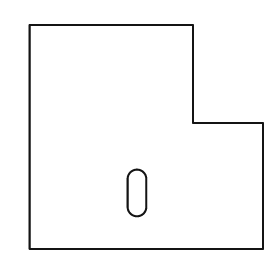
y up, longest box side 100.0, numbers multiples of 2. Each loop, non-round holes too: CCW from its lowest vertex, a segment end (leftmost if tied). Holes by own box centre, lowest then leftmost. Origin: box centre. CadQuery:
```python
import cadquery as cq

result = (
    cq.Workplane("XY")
    .moveTo(-50.0, -48.0)
    .lineTo(50.0, -48.0)
    .lineTo(50.0, 6.0)
    .lineTo(20.0, 6.0)
    .lineTo(20.0, 48.0)
    .lineTo(-50.0, 48.0)
    .close()
    .moveTo(-8.0, -30.0)
    .threePointArc((-4.0, -34.0), (0.0, -30.0))
    .lineTo(0.0, -18.0)
    .threePointArc((-4.0, -14.0), (-8.0, -18.0))
    .close()
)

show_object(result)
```